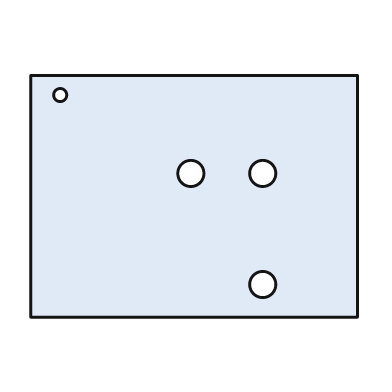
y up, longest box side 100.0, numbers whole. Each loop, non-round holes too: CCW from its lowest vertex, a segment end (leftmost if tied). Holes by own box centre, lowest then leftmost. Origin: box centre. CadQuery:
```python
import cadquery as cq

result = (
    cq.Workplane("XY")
    .moveTo(-50.0, -37.0)
    .lineTo(50.0, -37.0)
    .lineTo(50.0, 37.0)
    .lineTo(-50.0, 37.0)
    .close()
    .moveTo(21.0, -27.0)
    .circle(4.0)
    .moveTo(-1.0, 7.0)
    .circle(4.0)
    .moveTo(21.0, 7.0)
    .circle(4.0)
    .moveTo(-41.0, 31.0)
    .circle(2.0)
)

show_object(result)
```